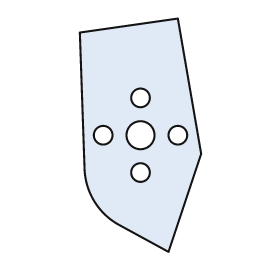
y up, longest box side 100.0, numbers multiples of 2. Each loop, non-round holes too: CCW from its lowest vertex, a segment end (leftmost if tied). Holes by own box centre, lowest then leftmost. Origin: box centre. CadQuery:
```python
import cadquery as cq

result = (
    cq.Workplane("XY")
    .moveTo(12.0, -50.0)
    .lineTo(26.0, -8.0)
    .lineTo(16.0, 50.0)
    .lineTo(-26.0, 44.0)
    .lineTo(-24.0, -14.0)
    .threePointArc((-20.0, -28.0), (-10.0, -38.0))
    .close()
    .moveTo(0.0, -16.0)
    .circle(4.0)
    .moveTo(-16.0, 0.0)
    .circle(4.0)
    .moveTo(0.0, 0.0)
    .circle(6.0)
    .moveTo(16.0, 0.0)
    .circle(4.0)
    .moveTo(0.0, 16.0)
    .circle(4.0)
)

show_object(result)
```